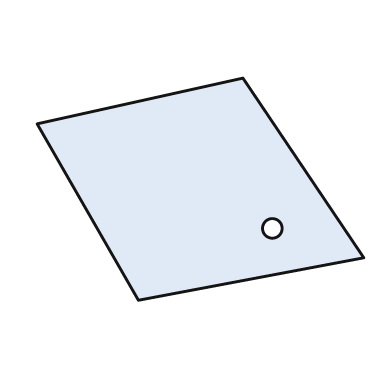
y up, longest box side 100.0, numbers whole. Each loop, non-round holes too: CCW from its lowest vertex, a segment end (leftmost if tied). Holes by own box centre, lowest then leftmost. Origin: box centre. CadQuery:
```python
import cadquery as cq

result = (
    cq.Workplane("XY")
    .moveTo(-19.0, -34.0)
    .lineTo(50.0, -21.0)
    .lineTo(13.0, 34.0)
    .lineTo(-50.0, 20.0)
    .close()
    .moveTo(22.0, -12.0)
    .circle(3.0)
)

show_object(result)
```